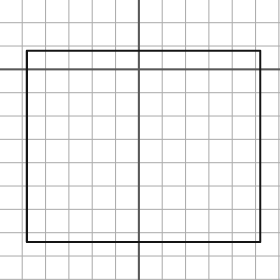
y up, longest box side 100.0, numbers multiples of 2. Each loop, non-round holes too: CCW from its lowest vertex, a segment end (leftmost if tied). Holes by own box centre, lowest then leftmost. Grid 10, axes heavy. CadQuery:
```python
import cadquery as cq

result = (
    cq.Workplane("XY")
    .moveTo(-48.0, -74.0)
    .lineTo(52.0, -74.0)
    .lineTo(52.0, 8.0)
    .lineTo(-48.0, 8.0)
    .close()
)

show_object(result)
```